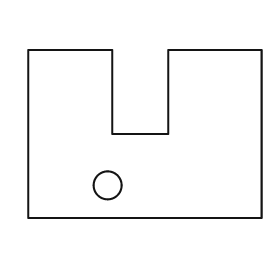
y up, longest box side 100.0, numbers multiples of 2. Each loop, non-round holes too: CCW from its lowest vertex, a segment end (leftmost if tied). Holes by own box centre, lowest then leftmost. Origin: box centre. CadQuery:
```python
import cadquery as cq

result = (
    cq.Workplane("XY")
    .moveTo(-50.0, -36.0)
    .lineTo(50.0, -36.0)
    .lineTo(50.0, 36.0)
    .lineTo(10.0, 36.0)
    .lineTo(10.0, 0.0)
    .lineTo(-14.0, 0.0)
    .lineTo(-14.0, 36.0)
    .lineTo(-50.0, 36.0)
    .close()
    .moveTo(-16.0, -22.0)
    .circle(6.0)
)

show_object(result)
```